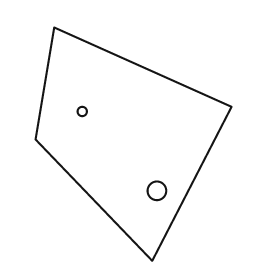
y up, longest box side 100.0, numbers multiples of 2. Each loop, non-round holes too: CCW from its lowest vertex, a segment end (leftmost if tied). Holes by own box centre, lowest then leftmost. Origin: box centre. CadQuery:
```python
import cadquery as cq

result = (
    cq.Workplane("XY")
    .moveTo(8.0, -50.0)
    .lineTo(42.0, 16.0)
    .lineTo(-34.0, 50.0)
    .lineTo(-42.0, 2.0)
    .close()
    .moveTo(10.0, -20.0)
    .circle(4.0)
    .moveTo(-22.0, 14.0)
    .circle(2.0)
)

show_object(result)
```